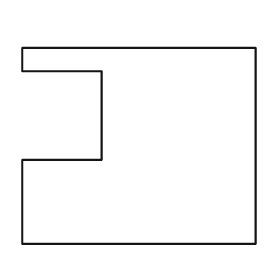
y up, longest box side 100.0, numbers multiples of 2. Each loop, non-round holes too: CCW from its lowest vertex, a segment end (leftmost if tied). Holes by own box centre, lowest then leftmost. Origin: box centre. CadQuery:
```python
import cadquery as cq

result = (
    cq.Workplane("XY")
    .moveTo(-50.0, -42.0)
    .lineTo(50.0, -42.0)
    .lineTo(50.0, 42.0)
    .lineTo(-50.0, 42.0)
    .lineTo(-50.0, 32.0)
    .lineTo(-16.0, 32.0)
    .lineTo(-16.0, -6.0)
    .lineTo(-50.0, -6.0)
    .close()
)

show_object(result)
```